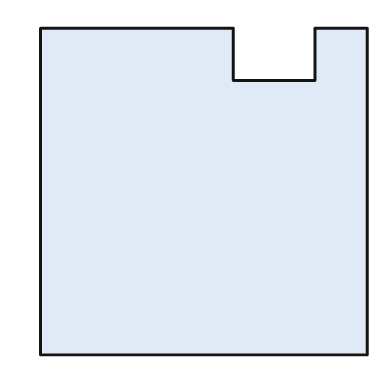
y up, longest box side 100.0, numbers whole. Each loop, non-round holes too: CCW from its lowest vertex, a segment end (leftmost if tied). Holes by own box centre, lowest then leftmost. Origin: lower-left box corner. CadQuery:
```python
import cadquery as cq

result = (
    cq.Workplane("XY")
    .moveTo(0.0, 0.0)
    .lineTo(100.0, 0.0)
    .lineTo(100.0, 100.0)
    .lineTo(84.0, 100.0)
    .lineTo(84.0, 84.0)
    .lineTo(59.0, 84.0)
    .lineTo(59.0, 100.0)
    .lineTo(0.0, 100.0)
    .close()
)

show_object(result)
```